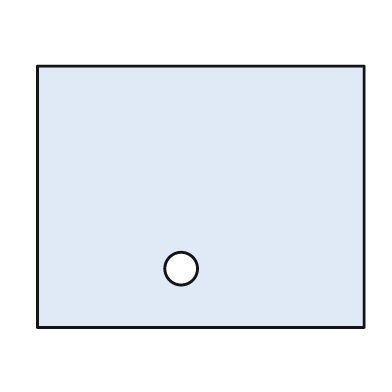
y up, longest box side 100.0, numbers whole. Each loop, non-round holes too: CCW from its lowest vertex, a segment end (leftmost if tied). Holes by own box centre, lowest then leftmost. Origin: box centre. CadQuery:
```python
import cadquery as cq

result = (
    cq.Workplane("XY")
    .moveTo(-50.0, -40.0)
    .lineTo(50.0, -40.0)
    .lineTo(50.0, 40.0)
    .lineTo(-50.0, 40.0)
    .close()
    .moveTo(-6.0, -22.0)
    .circle(5.0)
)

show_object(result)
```